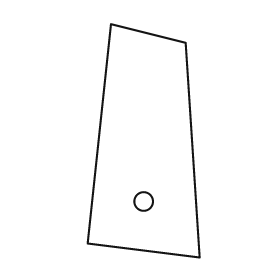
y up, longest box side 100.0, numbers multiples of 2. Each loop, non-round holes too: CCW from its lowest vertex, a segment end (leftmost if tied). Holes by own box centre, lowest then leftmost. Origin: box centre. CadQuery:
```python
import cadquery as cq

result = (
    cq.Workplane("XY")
    .moveTo(24.0, -50.0)
    .lineTo(18.0, 42.0)
    .lineTo(-14.0, 50.0)
    .lineTo(-24.0, -44.0)
    .close()
    .moveTo(0.0, -26.0)
    .circle(4.0)
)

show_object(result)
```